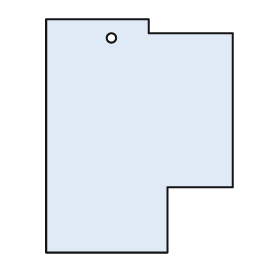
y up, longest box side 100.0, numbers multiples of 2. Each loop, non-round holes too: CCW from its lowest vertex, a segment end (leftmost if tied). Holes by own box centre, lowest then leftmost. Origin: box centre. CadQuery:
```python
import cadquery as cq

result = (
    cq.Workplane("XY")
    .moveTo(-40.0, -50.0)
    .lineTo(12.0, -50.0)
    .lineTo(12.0, -22.0)
    .lineTo(40.0, -22.0)
    .lineTo(40.0, 44.0)
    .lineTo(4.0, 44.0)
    .lineTo(4.0, 50.0)
    .lineTo(-40.0, 50.0)
    .close()
    .moveTo(-12.0, 42.0)
    .circle(2.0)
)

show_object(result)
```